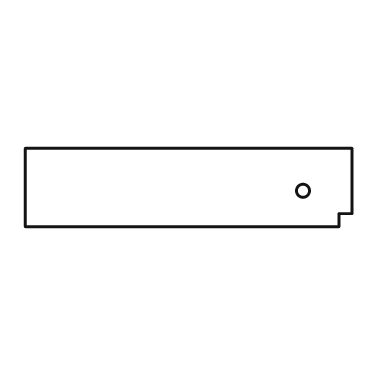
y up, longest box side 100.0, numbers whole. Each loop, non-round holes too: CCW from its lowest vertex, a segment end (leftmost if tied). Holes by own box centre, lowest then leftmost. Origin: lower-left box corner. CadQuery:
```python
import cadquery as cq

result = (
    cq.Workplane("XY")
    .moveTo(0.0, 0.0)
    .lineTo(96.0, 0.0)
    .lineTo(96.0, 4.0)
    .lineTo(100.0, 4.0)
    .lineTo(100.0, 24.0)
    .lineTo(0.0, 24.0)
    .close()
    .moveTo(85.0, 11.0)
    .circle(2.0)
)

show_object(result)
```